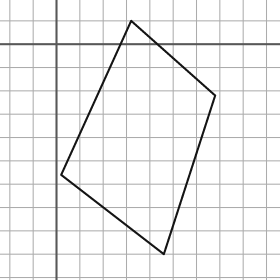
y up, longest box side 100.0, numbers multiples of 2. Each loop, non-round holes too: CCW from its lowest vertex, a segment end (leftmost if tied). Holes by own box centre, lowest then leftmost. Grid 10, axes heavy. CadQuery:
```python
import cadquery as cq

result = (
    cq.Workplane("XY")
    .moveTo(46.0, -90.0)
    .lineTo(68.0, -22.0)
    .lineTo(32.0, 10.0)
    .lineTo(2.0, -56.0)
    .close()
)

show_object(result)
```